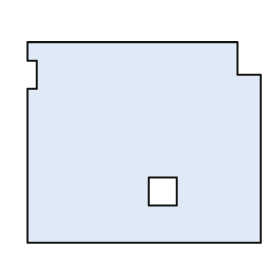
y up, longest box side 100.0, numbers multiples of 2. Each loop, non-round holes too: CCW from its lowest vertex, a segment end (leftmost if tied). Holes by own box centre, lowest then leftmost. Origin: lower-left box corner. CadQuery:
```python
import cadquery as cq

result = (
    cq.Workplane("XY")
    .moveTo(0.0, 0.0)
    .lineTo(100.0, 0.0)
    .lineTo(100.0, 72.0)
    .lineTo(90.0, 72.0)
    .lineTo(90.0, 86.0)
    .lineTo(0.0, 86.0)
    .lineTo(0.0, 78.0)
    .lineTo(4.0, 78.0)
    .lineTo(4.0, 66.0)
    .lineTo(0.0, 66.0)
    .close()
    .moveTo(52.0, 16.0)
    .lineTo(64.0, 16.0)
    .lineTo(64.0, 28.0)
    .lineTo(52.0, 28.0)
    .close()
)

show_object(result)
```